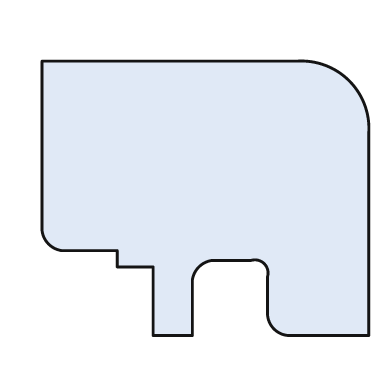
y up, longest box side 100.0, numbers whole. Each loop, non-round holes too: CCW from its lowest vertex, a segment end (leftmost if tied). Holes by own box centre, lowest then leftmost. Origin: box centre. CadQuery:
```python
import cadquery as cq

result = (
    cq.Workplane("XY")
    .moveTo(-16.0, -42.0)
    .lineTo(-4.0, -42.0)
    .lineTo(-4.0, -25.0)
    .threePointArc((-2.0, -21.0), (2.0, -19.0))
    .lineTo(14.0, -19.0)
    .threePointArc((18.0, -20.0), (19.0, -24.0))
    .lineTo(19.0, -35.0)
    .threePointArc((21.0, -40.0), (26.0, -42.0))
    .lineTo(50.0, -42.0)
    .lineTo(50.0, 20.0)
    .threePointArc((44.0, 36.0), (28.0, 42.0))
    .lineTo(-50.0, 42.0)
    .lineTo(-50.0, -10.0)
    .threePointArc((-48.0, -14.0), (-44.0, -16.0))
    .lineTo(-27.0, -16.0)
    .lineTo(-27.0, -21.0)
    .lineTo(-16.0, -21.0)
    .close()
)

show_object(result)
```